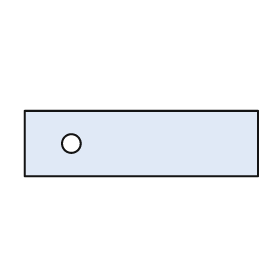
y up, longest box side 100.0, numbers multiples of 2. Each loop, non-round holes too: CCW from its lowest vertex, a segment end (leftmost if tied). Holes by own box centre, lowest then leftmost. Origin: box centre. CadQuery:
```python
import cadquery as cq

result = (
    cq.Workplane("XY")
    .moveTo(-50.0, -14.0)
    .lineTo(50.0, -14.0)
    .lineTo(50.0, 14.0)
    .lineTo(-50.0, 14.0)
    .close()
    .moveTo(-30.0, 0.0)
    .circle(4.0)
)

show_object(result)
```